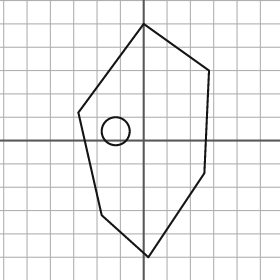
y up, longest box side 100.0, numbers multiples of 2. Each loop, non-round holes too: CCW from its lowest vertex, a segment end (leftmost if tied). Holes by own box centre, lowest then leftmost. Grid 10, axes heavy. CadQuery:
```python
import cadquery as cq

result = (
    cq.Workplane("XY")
    .moveTo(2.0, -50.0)
    .lineTo(26.0, -14.0)
    .lineTo(28.0, 30.0)
    .lineTo(0.0, 50.0)
    .lineTo(-28.0, 12.0)
    .lineTo(-18.0, -32.0)
    .close()
    .moveTo(-12.0, 4.0)
    .circle(6.0)
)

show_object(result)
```